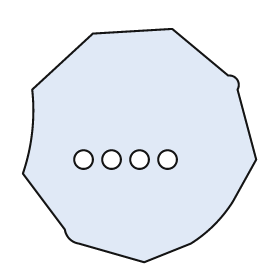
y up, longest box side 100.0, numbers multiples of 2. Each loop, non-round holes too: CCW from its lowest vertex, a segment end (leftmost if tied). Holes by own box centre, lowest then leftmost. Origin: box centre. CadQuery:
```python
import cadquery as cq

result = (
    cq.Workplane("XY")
    .moveTo(2.0, -50.0)
    .lineTo(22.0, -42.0)
    .threePointArc((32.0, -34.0), (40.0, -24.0))
    .lineTo(50.0, -6.0)
    .lineTo(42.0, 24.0)
    .threePointArc((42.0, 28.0), (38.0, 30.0))
    .lineTo(14.0, 50.0)
    .lineTo(-20.0, 48.0)
    .lineTo(-46.0, 24.0)
    .threePointArc((-46.0, 6.0), (-50.0, -12.0))
    .lineTo(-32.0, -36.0)
    .threePointArc((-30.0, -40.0), (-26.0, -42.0))
    .close()
    .moveTo(-24.0, -6.0)
    .circle(4.0)
    .moveTo(-12.0, -6.0)
    .circle(4.0)
    .moveTo(0.0, -6.0)
    .circle(4.0)
    .moveTo(12.0, -6.0)
    .circle(4.0)
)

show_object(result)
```